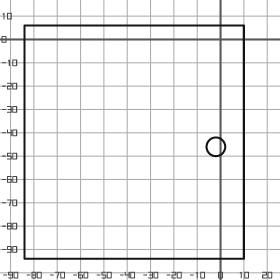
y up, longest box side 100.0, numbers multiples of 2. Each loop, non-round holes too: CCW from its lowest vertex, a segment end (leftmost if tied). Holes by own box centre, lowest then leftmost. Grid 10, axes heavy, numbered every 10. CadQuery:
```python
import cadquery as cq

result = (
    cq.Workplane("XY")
    .moveTo(-84.0, -94.0)
    .lineTo(10.0, -94.0)
    .lineTo(10.0, 6.0)
    .lineTo(-84.0, 6.0)
    .close()
    .moveTo(-2.0, -46.0)
    .circle(4.0)
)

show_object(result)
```